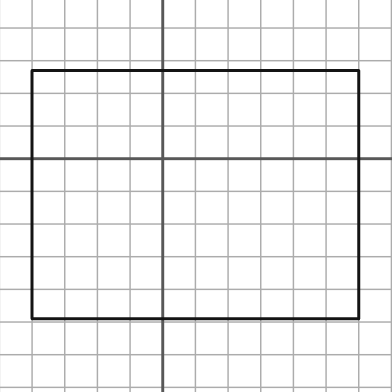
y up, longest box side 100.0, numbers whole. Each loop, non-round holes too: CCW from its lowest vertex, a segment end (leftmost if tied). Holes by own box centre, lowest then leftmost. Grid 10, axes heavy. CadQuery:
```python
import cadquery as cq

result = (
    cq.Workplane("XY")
    .moveTo(-40.0, -49.0)
    .lineTo(60.0, -49.0)
    .lineTo(60.0, 27.0)
    .lineTo(-40.0, 27.0)
    .close()
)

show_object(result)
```